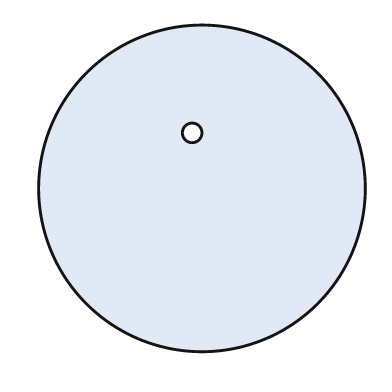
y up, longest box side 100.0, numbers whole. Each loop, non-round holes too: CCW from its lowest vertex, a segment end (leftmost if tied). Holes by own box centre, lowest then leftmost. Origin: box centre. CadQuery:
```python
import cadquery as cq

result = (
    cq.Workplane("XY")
    .moveTo(0.0, 0.0)
    .circle(50.0)
    .moveTo(-3.0, 17.0)
    .circle(3.0)
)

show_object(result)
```